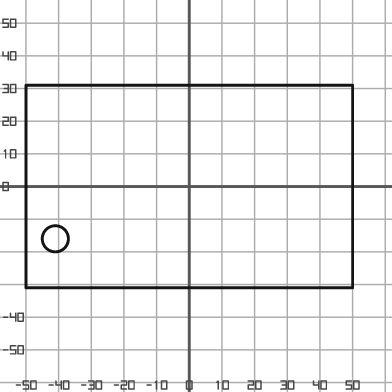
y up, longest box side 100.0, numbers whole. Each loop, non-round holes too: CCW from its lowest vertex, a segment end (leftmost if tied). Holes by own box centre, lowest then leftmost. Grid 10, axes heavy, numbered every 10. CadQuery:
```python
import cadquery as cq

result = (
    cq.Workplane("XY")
    .moveTo(-50.0, -31.0)
    .lineTo(50.0, -31.0)
    .lineTo(50.0, 31.0)
    .lineTo(-50.0, 31.0)
    .close()
    .moveTo(-41.0, -16.0)
    .circle(4.0)
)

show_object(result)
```